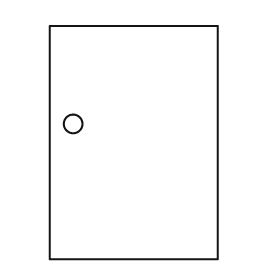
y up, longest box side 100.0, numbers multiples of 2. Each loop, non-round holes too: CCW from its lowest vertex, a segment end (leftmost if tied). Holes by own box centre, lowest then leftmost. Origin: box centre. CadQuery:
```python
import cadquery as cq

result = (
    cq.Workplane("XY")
    .moveTo(-36.0, -50.0)
    .lineTo(36.0, -50.0)
    .lineTo(36.0, 50.0)
    .lineTo(-36.0, 50.0)
    .close()
    .moveTo(-26.0, 8.0)
    .circle(4.0)
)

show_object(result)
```